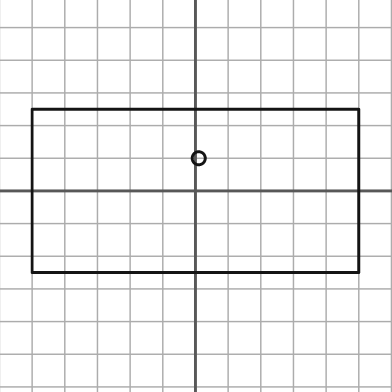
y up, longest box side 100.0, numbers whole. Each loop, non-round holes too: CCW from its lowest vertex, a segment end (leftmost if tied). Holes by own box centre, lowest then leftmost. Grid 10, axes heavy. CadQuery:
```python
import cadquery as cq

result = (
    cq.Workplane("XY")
    .moveTo(-50.0, -25.0)
    .lineTo(50.0, -25.0)
    .lineTo(50.0, 25.0)
    .lineTo(-50.0, 25.0)
    .close()
    .moveTo(1.0, 10.0)
    .circle(2.0)
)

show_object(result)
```